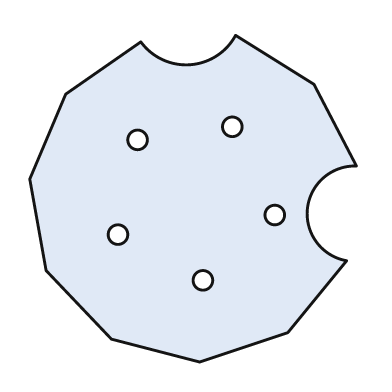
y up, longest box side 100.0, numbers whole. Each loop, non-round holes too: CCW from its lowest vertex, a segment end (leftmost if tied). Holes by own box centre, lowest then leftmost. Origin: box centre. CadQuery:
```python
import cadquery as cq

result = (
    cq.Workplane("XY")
    .moveTo(2.0, -50.0)
    .lineTo(29.0, -41.0)
    .lineTo(47.0, -19.0)
    .threePointArc((35.0, -3.0), (50.0, 10.0))
    .lineTo(37.0, 35.0)
    .lineTo(13.0, 50.0)
    .threePointArc((-1.0, 41.0), (-16.0, 48.0))
    .lineTo(-39.0, 32.0)
    .lineTo(-50.0, 6.0)
    .lineTo(-45.0, -22.0)
    .lineTo(-25.0, -43.0)
    .close()
    .moveTo(3.0, -25.0)
    .circle(3.0)
    .moveTo(-23.0, -11.0)
    .circle(3.0)
    .moveTo(25.0, -5.0)
    .circle(3.0)
    .moveTo(-17.0, 18.0)
    .circle(3.0)
    .moveTo(12.0, 22.0)
    .circle(3.0)
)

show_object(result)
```